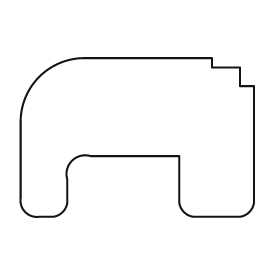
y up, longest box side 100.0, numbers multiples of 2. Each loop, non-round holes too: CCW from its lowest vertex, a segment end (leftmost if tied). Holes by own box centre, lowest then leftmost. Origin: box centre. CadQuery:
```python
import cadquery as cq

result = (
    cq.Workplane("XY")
    .moveTo(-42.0, -34.0)
    .lineTo(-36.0, -34.0)
    .threePointArc((-32.0, -32.0), (-30.0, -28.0))
    .lineTo(-30.0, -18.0)
    .threePointArc((-28.0, -10.0), (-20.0, -8.0))
    .lineTo(18.0, -8.0)
    .lineTo(18.0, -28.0)
    .threePointArc((20.0, -32.0), (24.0, -34.0))
    .lineTo(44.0, -34.0)
    .threePointArc((48.0, -32.0), (50.0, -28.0))
    .lineTo(50.0, 22.0)
    .lineTo(44.0, 22.0)
    .lineTo(44.0, 30.0)
    .lineTo(32.0, 30.0)
    .lineTo(32.0, 34.0)
    .lineTo(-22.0, 34.0)
    .threePointArc((-42.0, 26.0), (-50.0, 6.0))
    .lineTo(-50.0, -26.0)
    .threePointArc((-48.0, -32.0), (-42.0, -34.0))
    .close()
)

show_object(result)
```